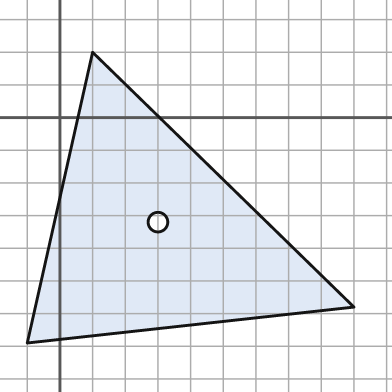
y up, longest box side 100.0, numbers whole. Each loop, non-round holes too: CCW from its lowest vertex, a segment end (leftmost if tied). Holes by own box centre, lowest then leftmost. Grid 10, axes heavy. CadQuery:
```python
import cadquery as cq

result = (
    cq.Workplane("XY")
    .moveTo(-10.0, -69.0)
    .lineTo(90.0, -58.0)
    .lineTo(10.0, 20.0)
    .close()
    .moveTo(30.0, -32.0)
    .circle(3.0)
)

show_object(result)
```